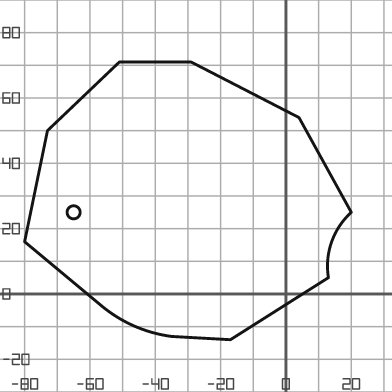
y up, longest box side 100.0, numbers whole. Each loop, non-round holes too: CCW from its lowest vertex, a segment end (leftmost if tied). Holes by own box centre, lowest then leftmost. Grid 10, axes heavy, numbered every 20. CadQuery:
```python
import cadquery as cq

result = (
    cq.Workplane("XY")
    .moveTo(-17.0, -14.0)
    .lineTo(13.0, 5.0)
    .threePointArc((14.0, 16.0), (20.0, 25.0))
    .lineTo(4.0, 54.0)
    .lineTo(-29.0, 71.0)
    .lineTo(-51.0, 71.0)
    .lineTo(-73.0, 50.0)
    .lineTo(-80.0, 16.0)
    .lineTo(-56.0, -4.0)
    .threePointArc((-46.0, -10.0), (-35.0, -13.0))
    .close()
    .moveTo(-65.0, 25.0)
    .circle(2.0)
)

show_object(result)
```